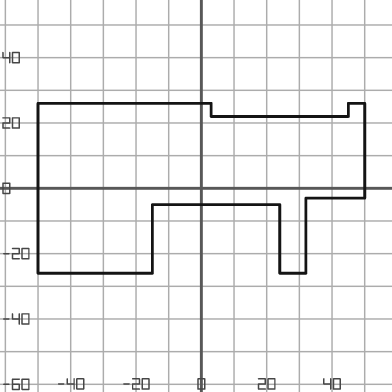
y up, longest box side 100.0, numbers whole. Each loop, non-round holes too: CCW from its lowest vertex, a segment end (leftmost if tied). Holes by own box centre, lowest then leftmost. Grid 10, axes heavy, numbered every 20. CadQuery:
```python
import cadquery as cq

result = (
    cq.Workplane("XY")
    .moveTo(-50.0, -26.0)
    .lineTo(-15.0, -26.0)
    .lineTo(-15.0, -5.0)
    .lineTo(24.0, -5.0)
    .lineTo(24.0, -26.0)
    .lineTo(32.0, -26.0)
    .lineTo(32.0, -3.0)
    .lineTo(50.0, -3.0)
    .lineTo(50.0, 26.0)
    .lineTo(45.0, 26.0)
    .lineTo(45.0, 22.0)
    .lineTo(3.0, 22.0)
    .lineTo(3.0, 26.0)
    .lineTo(-50.0, 26.0)
    .close()
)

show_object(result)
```